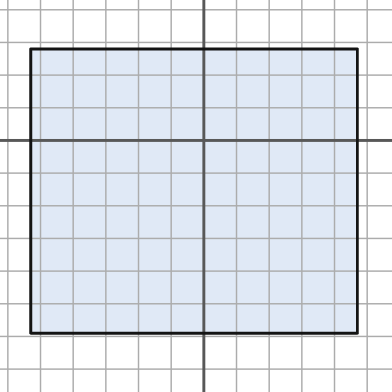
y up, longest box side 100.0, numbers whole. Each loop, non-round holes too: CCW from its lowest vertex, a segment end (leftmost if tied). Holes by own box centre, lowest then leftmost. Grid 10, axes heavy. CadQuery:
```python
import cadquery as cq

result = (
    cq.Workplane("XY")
    .moveTo(-53.0, -59.0)
    .lineTo(47.0, -59.0)
    .lineTo(47.0, 28.0)
    .lineTo(-53.0, 28.0)
    .close()
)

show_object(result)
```